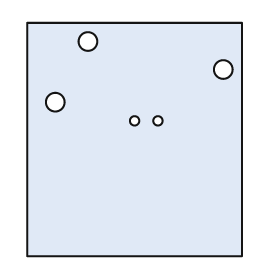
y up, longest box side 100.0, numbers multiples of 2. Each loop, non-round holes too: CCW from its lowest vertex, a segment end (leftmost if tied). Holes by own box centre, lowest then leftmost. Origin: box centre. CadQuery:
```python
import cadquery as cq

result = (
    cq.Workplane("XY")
    .moveTo(-46.0, -50.0)
    .lineTo(46.0, -50.0)
    .lineTo(46.0, 50.0)
    .lineTo(-46.0, 50.0)
    .close()
    .moveTo(0.0, 8.0)
    .circle(2.0)
    .moveTo(10.0, 8.0)
    .circle(2.0)
    .moveTo(-34.0, 16.0)
    .circle(4.0)
    .moveTo(38.0, 30.0)
    .circle(4.0)
    .moveTo(-20.0, 42.0)
    .circle(4.0)
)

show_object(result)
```